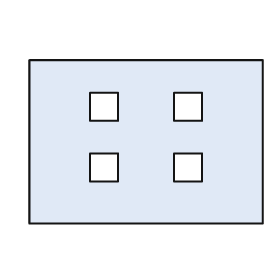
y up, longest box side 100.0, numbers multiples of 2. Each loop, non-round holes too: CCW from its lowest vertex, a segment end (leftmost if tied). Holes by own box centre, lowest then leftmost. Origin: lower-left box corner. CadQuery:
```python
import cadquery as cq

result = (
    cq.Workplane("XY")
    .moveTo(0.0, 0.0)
    .lineTo(100.0, 0.0)
    .lineTo(100.0, 70.0)
    .lineTo(0.0, 70.0)
    .close()
    .moveTo(26.0, 18.0)
    .lineTo(38.0, 18.0)
    .lineTo(38.0, 30.0)
    .lineTo(26.0, 30.0)
    .close()
    .moveTo(62.0, 18.0)
    .lineTo(74.0, 18.0)
    .lineTo(74.0, 30.0)
    .lineTo(62.0, 30.0)
    .close()
    .moveTo(26.0, 44.0)
    .lineTo(38.0, 44.0)
    .lineTo(38.0, 56.0)
    .lineTo(26.0, 56.0)
    .close()
    .moveTo(62.0, 44.0)
    .lineTo(74.0, 44.0)
    .lineTo(74.0, 56.0)
    .lineTo(62.0, 56.0)
    .close()
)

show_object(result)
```